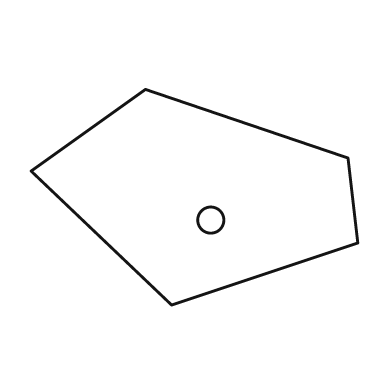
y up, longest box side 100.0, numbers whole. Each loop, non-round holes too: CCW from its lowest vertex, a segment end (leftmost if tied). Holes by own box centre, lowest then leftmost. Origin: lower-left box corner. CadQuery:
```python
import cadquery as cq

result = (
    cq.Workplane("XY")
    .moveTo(43.0, 0.0)
    .lineTo(100.0, 19.0)
    .lineTo(97.0, 45.0)
    .lineTo(35.0, 66.0)
    .lineTo(0.0, 41.0)
    .close()
    .moveTo(55.0, 26.0)
    .circle(4.0)
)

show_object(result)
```